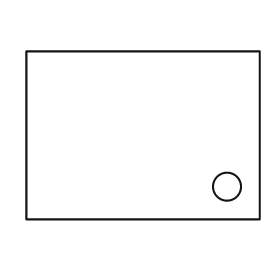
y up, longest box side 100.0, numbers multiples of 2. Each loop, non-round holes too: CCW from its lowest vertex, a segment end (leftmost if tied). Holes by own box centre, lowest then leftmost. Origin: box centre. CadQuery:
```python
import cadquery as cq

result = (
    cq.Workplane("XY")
    .moveTo(-50.0, -36.0)
    .lineTo(50.0, -36.0)
    .lineTo(50.0, 36.0)
    .lineTo(-50.0, 36.0)
    .close()
    .moveTo(36.0, -22.0)
    .circle(6.0)
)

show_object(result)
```